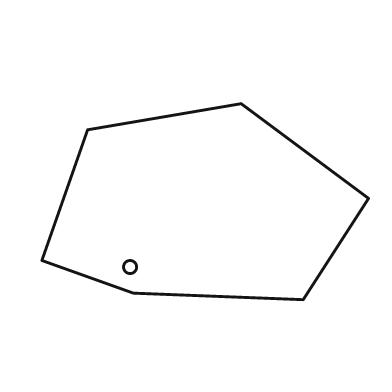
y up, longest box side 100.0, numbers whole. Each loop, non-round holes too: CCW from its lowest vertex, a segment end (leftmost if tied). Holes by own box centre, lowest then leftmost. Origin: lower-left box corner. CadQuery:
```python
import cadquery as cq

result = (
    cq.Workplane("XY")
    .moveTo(80.0, 0.0)
    .lineTo(100.0, 31.0)
    .lineTo(61.0, 60.0)
    .lineTo(14.0, 52.0)
    .lineTo(0.0, 12.0)
    .lineTo(28.0, 2.0)
    .close()
    .moveTo(27.0, 10.0)
    .circle(2.0)
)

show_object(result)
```